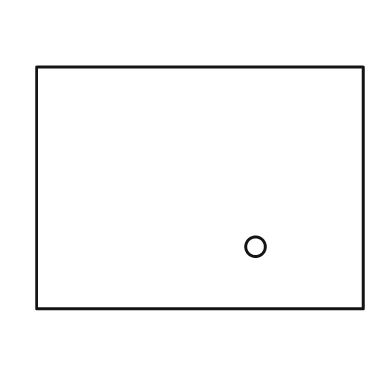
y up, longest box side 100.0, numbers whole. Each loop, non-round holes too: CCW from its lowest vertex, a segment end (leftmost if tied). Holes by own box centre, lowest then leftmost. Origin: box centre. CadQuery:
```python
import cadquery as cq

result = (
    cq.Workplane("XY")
    .moveTo(-50.0, -37.0)
    .lineTo(50.0, -37.0)
    .lineTo(50.0, 37.0)
    .lineTo(-50.0, 37.0)
    .close()
    .moveTo(17.0, -18.0)
    .circle(3.0)
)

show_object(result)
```